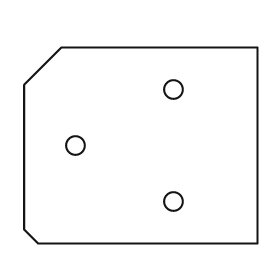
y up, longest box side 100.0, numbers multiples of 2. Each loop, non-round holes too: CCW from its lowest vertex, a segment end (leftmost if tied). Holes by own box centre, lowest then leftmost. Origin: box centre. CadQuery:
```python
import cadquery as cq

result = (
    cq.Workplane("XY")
    .moveTo(-44.0, -42.0)
    .lineTo(50.0, -42.0)
    .lineTo(50.0, 42.0)
    .lineTo(-34.0, 42.0)
    .lineTo(-50.0, 26.0)
    .lineTo(-50.0, -36.0)
    .close()
    .moveTo(14.0, -24.0)
    .circle(4.0)
    .moveTo(-28.0, 0.0)
    .circle(4.0)
    .moveTo(14.0, 24.0)
    .circle(4.0)
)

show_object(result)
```